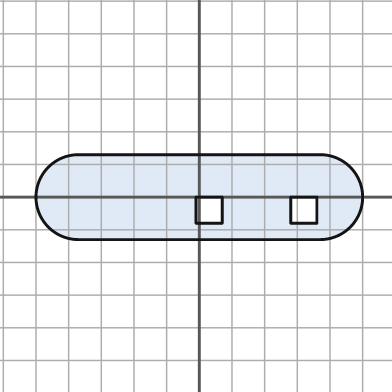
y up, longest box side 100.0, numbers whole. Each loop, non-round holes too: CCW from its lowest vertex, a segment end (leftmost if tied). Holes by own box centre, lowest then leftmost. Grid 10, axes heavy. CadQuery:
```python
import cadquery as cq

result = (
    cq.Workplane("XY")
    .moveTo(-37.0, -13.0)
    .lineTo(37.0, -13.0)
    .threePointArc((50.0, 0.0), (37.0, 13.0))
    .lineTo(-37.0, 13.0)
    .threePointArc((-50.0, 0.0), (-37.0, -13.0))
    .close()
    .moveTo(-1.0, -8.0)
    .lineTo(7.0, -8.0)
    .lineTo(7.0, 0.0)
    .lineTo(-1.0, 0.0)
    .close()
    .moveTo(28.0, -8.0)
    .lineTo(36.0, -8.0)
    .lineTo(36.0, 0.0)
    .lineTo(28.0, 0.0)
    .close()
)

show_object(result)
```